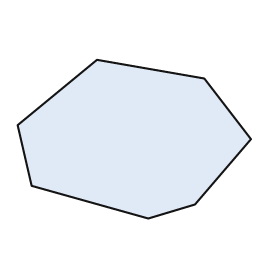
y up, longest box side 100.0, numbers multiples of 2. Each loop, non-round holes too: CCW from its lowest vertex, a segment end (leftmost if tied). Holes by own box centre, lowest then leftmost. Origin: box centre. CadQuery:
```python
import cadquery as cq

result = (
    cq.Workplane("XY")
    .moveTo(6.0, -34.0)
    .lineTo(26.0, -28.0)
    .lineTo(50.0, 0.0)
    .lineTo(30.0, 26.0)
    .lineTo(-16.0, 34.0)
    .lineTo(-50.0, 6.0)
    .lineTo(-44.0, -20.0)
    .close()
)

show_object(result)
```